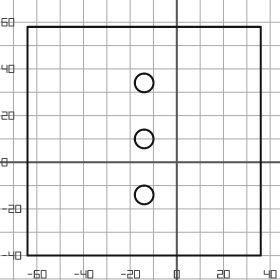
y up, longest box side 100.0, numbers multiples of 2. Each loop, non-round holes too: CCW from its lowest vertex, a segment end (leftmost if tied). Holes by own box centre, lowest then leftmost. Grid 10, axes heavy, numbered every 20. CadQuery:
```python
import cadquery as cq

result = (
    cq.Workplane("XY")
    .moveTo(-64.0, -40.0)
    .lineTo(36.0, -40.0)
    .lineTo(36.0, 58.0)
    .lineTo(-64.0, 58.0)
    .close()
    .moveTo(-14.0, -14.0)
    .circle(4.0)
    .moveTo(-14.0, 10.0)
    .circle(4.0)
    .moveTo(-14.0, 34.0)
    .circle(4.0)
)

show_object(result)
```